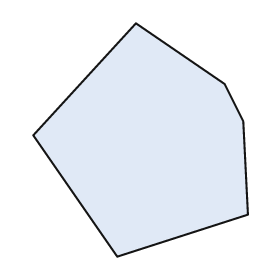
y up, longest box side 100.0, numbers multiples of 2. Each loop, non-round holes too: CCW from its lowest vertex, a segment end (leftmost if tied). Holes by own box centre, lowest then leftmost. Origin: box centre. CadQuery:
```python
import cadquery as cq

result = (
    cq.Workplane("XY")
    .moveTo(-10.0, -50.0)
    .lineTo(46.0, -32.0)
    .lineTo(44.0, 8.0)
    .lineTo(36.0, 24.0)
    .lineTo(-2.0, 50.0)
    .lineTo(-46.0, 2.0)
    .close()
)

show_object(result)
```